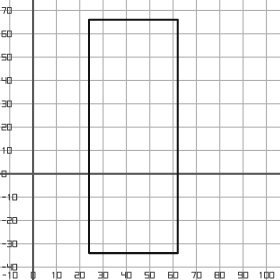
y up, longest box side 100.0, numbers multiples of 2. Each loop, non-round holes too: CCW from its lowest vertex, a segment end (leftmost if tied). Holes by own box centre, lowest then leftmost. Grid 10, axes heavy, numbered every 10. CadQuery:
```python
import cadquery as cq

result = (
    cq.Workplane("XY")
    .moveTo(24.0, -34.0)
    .lineTo(62.0, -34.0)
    .lineTo(62.0, 66.0)
    .lineTo(24.0, 66.0)
    .close()
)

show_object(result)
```